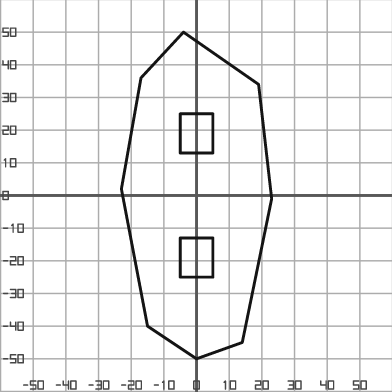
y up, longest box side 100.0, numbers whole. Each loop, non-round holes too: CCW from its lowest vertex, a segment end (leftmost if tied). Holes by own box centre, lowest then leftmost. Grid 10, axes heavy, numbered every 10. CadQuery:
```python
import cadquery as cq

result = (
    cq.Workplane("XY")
    .moveTo(0.0, -50.0)
    .lineTo(14.0, -45.0)
    .lineTo(23.0, -1.0)
    .lineTo(19.0, 34.0)
    .lineTo(-4.0, 50.0)
    .lineTo(-17.0, 36.0)
    .lineTo(-23.0, 2.0)
    .lineTo(-15.0, -40.0)
    .close()
    .moveTo(-5.0, -25.0)
    .lineTo(5.0, -25.0)
    .lineTo(5.0, -13.0)
    .lineTo(-5.0, -13.0)
    .close()
    .moveTo(-5.0, 13.0)
    .lineTo(5.0, 13.0)
    .lineTo(5.0, 25.0)
    .lineTo(-5.0, 25.0)
    .close()
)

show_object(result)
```